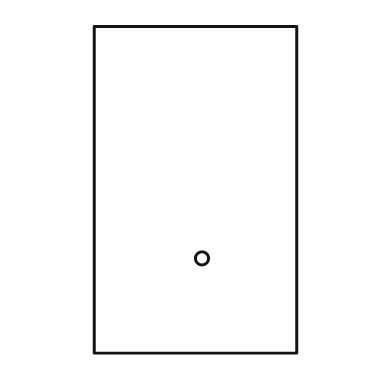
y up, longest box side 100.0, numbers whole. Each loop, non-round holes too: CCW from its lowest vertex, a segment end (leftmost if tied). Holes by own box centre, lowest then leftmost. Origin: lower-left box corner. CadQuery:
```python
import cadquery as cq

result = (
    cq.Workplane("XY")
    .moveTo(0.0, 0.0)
    .lineTo(62.0, 0.0)
    .lineTo(62.0, 100.0)
    .lineTo(0.0, 100.0)
    .close()
    .moveTo(33.0, 29.0)
    .circle(2.0)
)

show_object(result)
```